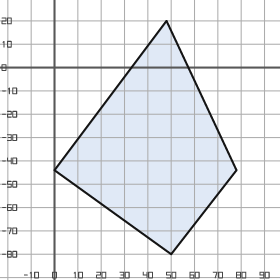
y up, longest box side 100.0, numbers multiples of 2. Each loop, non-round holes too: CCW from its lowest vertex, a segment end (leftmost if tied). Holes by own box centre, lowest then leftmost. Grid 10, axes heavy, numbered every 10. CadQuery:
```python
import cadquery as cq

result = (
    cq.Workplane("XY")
    .moveTo(50.0, -80.0)
    .lineTo(78.0, -44.0)
    .lineTo(48.0, 20.0)
    .lineTo(0.0, -44.0)
    .close()
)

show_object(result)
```